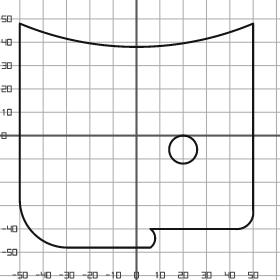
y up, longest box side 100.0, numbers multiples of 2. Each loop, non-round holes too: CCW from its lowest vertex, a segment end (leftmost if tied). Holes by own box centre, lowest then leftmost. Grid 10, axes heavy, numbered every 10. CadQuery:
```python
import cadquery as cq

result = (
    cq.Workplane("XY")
    .moveTo(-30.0, -48.0)
    .lineTo(6.0, -48.0)
    .threePointArc((8.0, -44.0), (6.0, -40.0))
    .lineTo(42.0, -40.0)
    .threePointArc((48.0, -38.0), (50.0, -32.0))
    .lineTo(50.0, 48.0)
    .threePointArc((0.0, 38.0), (-50.0, 48.0))
    .lineTo(-50.0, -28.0)
    .threePointArc((-44.0, -42.0), (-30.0, -48.0))
    .close()
    .moveTo(20.0, -6.0)
    .circle(6.0)
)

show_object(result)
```